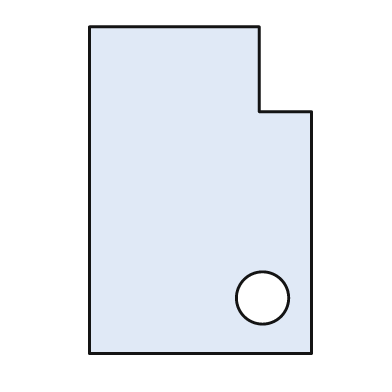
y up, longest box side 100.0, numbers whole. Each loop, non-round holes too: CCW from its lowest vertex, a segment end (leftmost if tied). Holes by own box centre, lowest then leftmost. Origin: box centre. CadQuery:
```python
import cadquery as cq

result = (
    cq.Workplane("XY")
    .moveTo(-34.0, -50.0)
    .lineTo(34.0, -50.0)
    .lineTo(34.0, 24.0)
    .lineTo(18.0, 24.0)
    .lineTo(18.0, 50.0)
    .lineTo(-34.0, 50.0)
    .close()
    .moveTo(19.0, -33.0)
    .circle(8.0)
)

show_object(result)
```